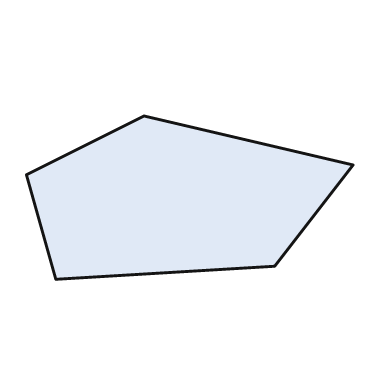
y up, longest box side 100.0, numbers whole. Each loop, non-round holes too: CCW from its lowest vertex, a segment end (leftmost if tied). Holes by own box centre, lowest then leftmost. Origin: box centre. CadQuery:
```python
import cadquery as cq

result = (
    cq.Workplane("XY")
    .moveTo(-41.0, -25.0)
    .lineTo(26.0, -21.0)
    .lineTo(50.0, 10.0)
    .lineTo(-14.0, 25.0)
    .lineTo(-50.0, 7.0)
    .close()
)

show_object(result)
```